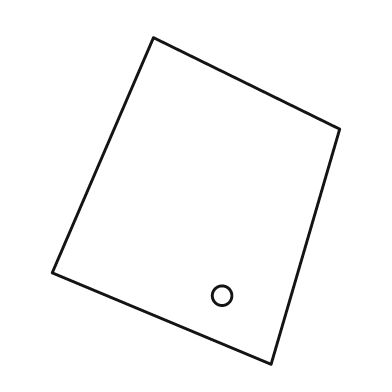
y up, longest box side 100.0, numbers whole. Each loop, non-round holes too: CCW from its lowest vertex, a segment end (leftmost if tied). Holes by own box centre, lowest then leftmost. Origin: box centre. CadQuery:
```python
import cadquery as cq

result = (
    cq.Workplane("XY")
    .moveTo(23.0, -50.0)
    .lineTo(44.0, 22.0)
    .lineTo(-13.0, 50.0)
    .lineTo(-44.0, -22.0)
    .close()
    .moveTo(8.0, -29.0)
    .circle(3.0)
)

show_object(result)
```